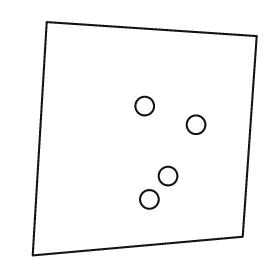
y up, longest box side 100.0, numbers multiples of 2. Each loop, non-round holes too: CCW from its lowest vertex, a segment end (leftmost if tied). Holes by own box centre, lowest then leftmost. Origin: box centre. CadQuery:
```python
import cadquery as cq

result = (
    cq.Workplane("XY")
    .moveTo(-48.0, -50.0)
    .lineTo(42.0, -42.0)
    .lineTo(48.0, 44.0)
    .lineTo(-42.0, 50.0)
    .close()
    .moveTo(2.0, -26.0)
    .circle(4.0)
    .moveTo(10.0, -16.0)
    .circle(4.0)
    .moveTo(22.0, 6.0)
    .circle(4.0)
    .moveTo(0.0, 14.0)
    .circle(4.0)
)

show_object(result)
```